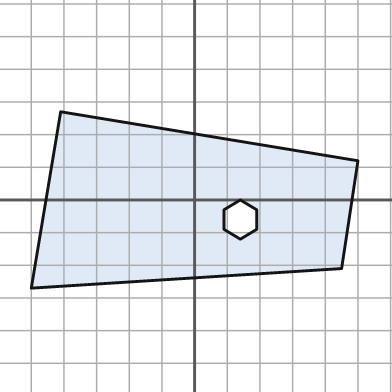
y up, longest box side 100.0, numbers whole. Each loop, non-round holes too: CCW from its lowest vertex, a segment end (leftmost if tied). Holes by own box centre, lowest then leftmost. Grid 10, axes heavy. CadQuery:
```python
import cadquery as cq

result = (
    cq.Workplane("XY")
    .moveTo(-50.0, -27.0)
    .lineTo(45.0, -21.0)
    .lineTo(50.0, 12.0)
    .lineTo(-41.0, 27.0)
    .close()
    .moveTo(14.0, -12.0)
    .lineTo(19.0, -9.0)
    .lineTo(19.0, -3.0)
    .lineTo(14.0, 0.0)
    .lineTo(9.0, -3.0)
    .lineTo(9.0, -9.0)
    .close()
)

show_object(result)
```